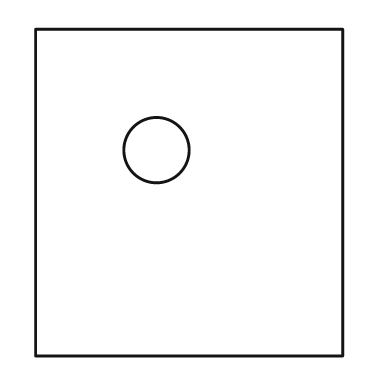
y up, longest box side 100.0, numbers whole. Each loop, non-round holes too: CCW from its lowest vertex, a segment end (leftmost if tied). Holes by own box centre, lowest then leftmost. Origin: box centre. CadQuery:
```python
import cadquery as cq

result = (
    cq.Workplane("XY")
    .moveTo(-47.0, -50.0)
    .lineTo(47.0, -50.0)
    .lineTo(47.0, 50.0)
    .lineTo(-47.0, 50.0)
    .close()
    .moveTo(-10.0, 13.0)
    .circle(10.0)
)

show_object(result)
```